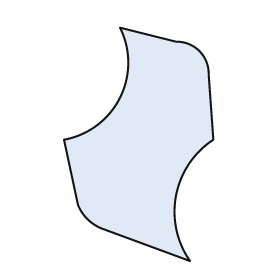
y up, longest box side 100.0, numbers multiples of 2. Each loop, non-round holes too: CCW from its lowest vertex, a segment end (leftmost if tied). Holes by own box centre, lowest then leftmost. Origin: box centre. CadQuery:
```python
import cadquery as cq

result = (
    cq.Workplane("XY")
    .moveTo(22.0, -50.0)
    .threePointArc((16.0, -22.0), (32.0, 2.0))
    .lineTo(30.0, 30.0)
    .threePointArc((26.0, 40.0), (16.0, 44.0))
    .lineTo(-8.0, 50.0)
    .threePointArc((-8.0, 20.0), (-32.0, 2.0))
    .lineTo(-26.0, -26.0)
    .threePointArc((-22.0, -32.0), (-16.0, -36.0))
    .close()
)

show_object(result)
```